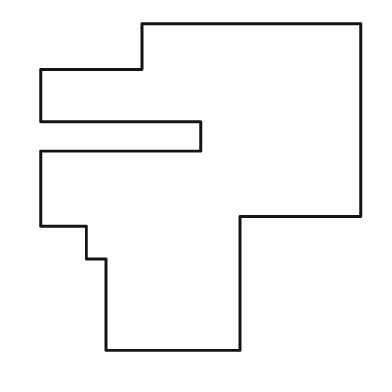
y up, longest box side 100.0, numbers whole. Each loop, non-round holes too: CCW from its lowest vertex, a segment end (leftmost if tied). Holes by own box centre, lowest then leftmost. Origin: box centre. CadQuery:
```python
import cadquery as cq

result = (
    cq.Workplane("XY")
    .moveTo(-29.0, -50.0)
    .lineTo(12.0, -50.0)
    .lineTo(12.0, -9.0)
    .lineTo(49.0, -9.0)
    .lineTo(49.0, 50.0)
    .lineTo(-18.0, 50.0)
    .lineTo(-18.0, 36.0)
    .lineTo(-49.0, 36.0)
    .lineTo(-49.0, 20.0)
    .lineTo(0.0, 20.0)
    .lineTo(0.0, 11.0)
    .lineTo(-49.0, 11.0)
    .lineTo(-49.0, -12.0)
    .lineTo(-35.0, -12.0)
    .lineTo(-35.0, -22.0)
    .lineTo(-29.0, -22.0)
    .close()
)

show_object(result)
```